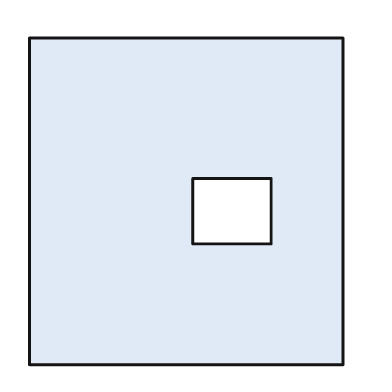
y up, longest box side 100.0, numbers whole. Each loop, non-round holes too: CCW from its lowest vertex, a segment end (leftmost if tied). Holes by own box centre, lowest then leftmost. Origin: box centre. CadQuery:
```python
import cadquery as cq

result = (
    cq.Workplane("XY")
    .moveTo(-48.0, -50.0)
    .lineTo(48.0, -50.0)
    .lineTo(48.0, 50.0)
    .lineTo(-48.0, 50.0)
    .close()
    .moveTo(2.0, -13.0)
    .lineTo(26.0, -13.0)
    .lineTo(26.0, 7.0)
    .lineTo(2.0, 7.0)
    .close()
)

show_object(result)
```